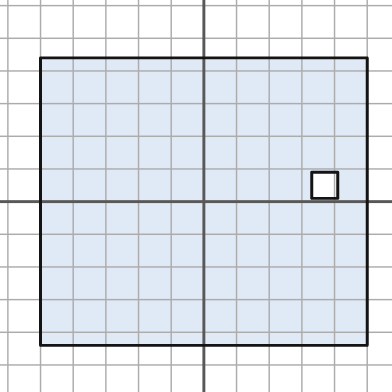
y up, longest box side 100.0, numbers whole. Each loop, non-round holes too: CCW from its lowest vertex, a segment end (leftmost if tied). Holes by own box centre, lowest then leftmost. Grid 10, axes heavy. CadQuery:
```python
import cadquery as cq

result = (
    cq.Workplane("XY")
    .moveTo(-50.0, -44.0)
    .lineTo(50.0, -44.0)
    .lineTo(50.0, 44.0)
    .lineTo(-50.0, 44.0)
    .close()
    .moveTo(33.0, 1.0)
    .lineTo(41.0, 1.0)
    .lineTo(41.0, 9.0)
    .lineTo(33.0, 9.0)
    .close()
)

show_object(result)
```